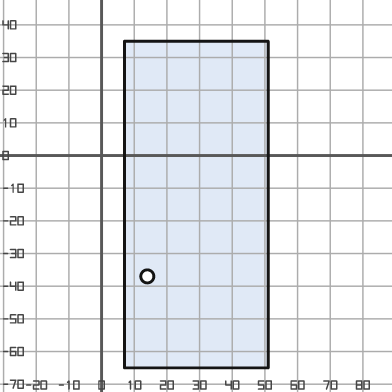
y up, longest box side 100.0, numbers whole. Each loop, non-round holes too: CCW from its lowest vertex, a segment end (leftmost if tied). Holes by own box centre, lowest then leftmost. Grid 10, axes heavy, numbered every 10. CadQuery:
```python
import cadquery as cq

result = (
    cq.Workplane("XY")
    .moveTo(7.0, -65.0)
    .lineTo(51.0, -65.0)
    .lineTo(51.0, 35.0)
    .lineTo(7.0, 35.0)
    .close()
    .moveTo(14.0, -37.0)
    .circle(2.0)
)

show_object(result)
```